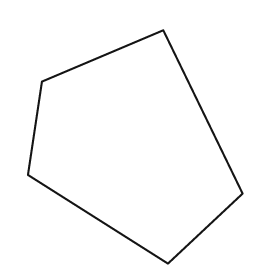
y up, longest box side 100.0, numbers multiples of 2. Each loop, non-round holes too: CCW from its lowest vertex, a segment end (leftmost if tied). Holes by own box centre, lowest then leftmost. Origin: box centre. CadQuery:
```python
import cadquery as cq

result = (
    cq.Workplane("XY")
    .moveTo(14.0, -50.0)
    .lineTo(46.0, -20.0)
    .lineTo(12.0, 50.0)
    .lineTo(-40.0, 28.0)
    .lineTo(-46.0, -12.0)
    .close()
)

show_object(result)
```